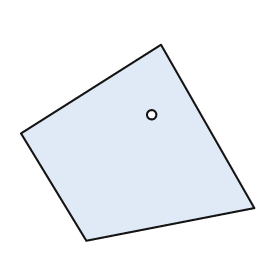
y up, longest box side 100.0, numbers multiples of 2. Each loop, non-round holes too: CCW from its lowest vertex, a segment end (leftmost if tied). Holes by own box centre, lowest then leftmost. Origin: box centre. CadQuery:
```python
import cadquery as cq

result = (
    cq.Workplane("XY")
    .moveTo(-22.0, -42.0)
    .lineTo(50.0, -28.0)
    .lineTo(10.0, 42.0)
    .lineTo(-50.0, 4.0)
    .close()
    .moveTo(6.0, 12.0)
    .circle(2.0)
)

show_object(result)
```